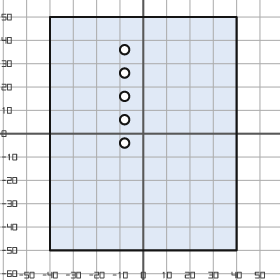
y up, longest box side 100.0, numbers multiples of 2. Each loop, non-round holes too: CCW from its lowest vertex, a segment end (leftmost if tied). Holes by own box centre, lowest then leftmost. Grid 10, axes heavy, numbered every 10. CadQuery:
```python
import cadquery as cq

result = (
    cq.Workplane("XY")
    .moveTo(-40.0, -50.0)
    .lineTo(40.0, -50.0)
    .lineTo(40.0, 50.0)
    .lineTo(-40.0, 50.0)
    .close()
    .moveTo(-8.0, -4.0)
    .circle(2.0)
    .moveTo(-8.0, 6.0)
    .circle(2.0)
    .moveTo(-8.0, 16.0)
    .circle(2.0)
    .moveTo(-8.0, 26.0)
    .circle(2.0)
    .moveTo(-8.0, 36.0)
    .circle(2.0)
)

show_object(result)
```